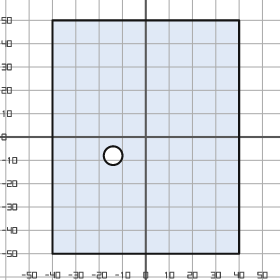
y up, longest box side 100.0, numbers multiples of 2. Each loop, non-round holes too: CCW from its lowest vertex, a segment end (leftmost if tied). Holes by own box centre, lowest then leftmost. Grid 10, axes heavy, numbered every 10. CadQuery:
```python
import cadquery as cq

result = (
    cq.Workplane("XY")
    .moveTo(-40.0, -50.0)
    .lineTo(40.0, -50.0)
    .lineTo(40.0, 50.0)
    .lineTo(-40.0, 50.0)
    .close()
    .moveTo(-14.0, -8.0)
    .circle(4.0)
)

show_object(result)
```